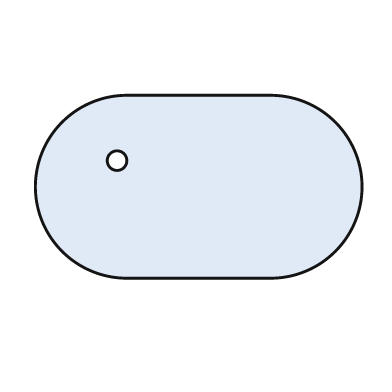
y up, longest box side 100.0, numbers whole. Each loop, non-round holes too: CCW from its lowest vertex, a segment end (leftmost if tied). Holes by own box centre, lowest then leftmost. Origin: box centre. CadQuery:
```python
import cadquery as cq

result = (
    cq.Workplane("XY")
    .moveTo(-22.0, -28.0)
    .lineTo(22.0, -28.0)
    .threePointArc((50.0, 0.0), (22.0, 28.0))
    .lineTo(-22.0, 28.0)
    .threePointArc((-50.0, 0.0), (-22.0, -28.0))
    .close()
    .moveTo(-25.0, 8.0)
    .circle(3.0)
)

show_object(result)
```